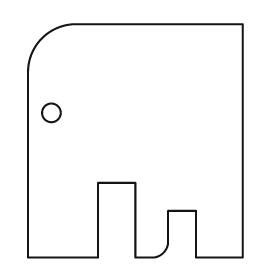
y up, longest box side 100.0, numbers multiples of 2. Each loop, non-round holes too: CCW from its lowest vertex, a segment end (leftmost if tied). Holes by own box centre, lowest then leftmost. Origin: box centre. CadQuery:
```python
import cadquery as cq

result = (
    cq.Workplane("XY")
    .moveTo(-46.0, -50.0)
    .lineTo(-16.0, -50.0)
    .lineTo(-16.0, -18.0)
    .lineTo(0.0, -18.0)
    .lineTo(0.0, -50.0)
    .lineTo(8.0, -50.0)
    .threePointArc((12.0, -48.0), (14.0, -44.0))
    .lineTo(14.0, -30.0)
    .lineTo(26.0, -30.0)
    .lineTo(26.0, -50.0)
    .lineTo(46.0, -50.0)
    .lineTo(46.0, 50.0)
    .lineTo(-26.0, 50.0)
    .threePointArc((-40.0, 44.0), (-46.0, 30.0))
    .close()
    .moveTo(-36.0, 12.0)
    .circle(4.0)
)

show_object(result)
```